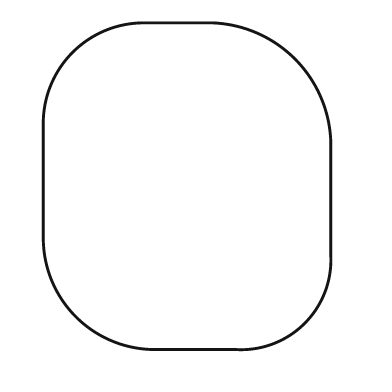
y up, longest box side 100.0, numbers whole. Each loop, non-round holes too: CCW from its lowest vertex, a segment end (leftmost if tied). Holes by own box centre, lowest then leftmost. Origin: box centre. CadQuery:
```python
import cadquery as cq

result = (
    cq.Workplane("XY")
    .moveTo(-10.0, -50.0)
    .lineTo(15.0, -50.0)
    .threePointArc((36.0, -42.0), (44.0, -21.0))
    .lineTo(44.0, 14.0)
    .threePointArc((33.0, 39.0), (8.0, 50.0))
    .lineTo(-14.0, 50.0)
    .threePointArc((-35.0, 41.0), (-44.0, 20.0))
    .lineTo(-44.0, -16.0)
    .threePointArc((-34.0, -40.0), (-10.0, -50.0))
    .close()
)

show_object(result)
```